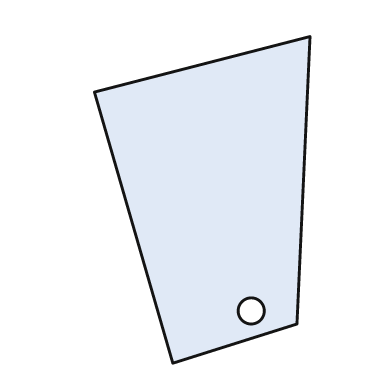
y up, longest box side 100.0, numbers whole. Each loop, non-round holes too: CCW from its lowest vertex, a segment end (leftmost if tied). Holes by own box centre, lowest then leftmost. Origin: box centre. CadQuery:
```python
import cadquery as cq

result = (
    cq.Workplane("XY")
    .moveTo(-9.0, -50.0)
    .lineTo(29.0, -38.0)
    .lineTo(33.0, 50.0)
    .lineTo(-33.0, 33.0)
    .close()
    .moveTo(15.0, -34.0)
    .circle(4.0)
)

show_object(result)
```